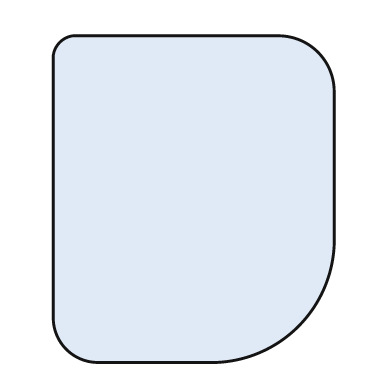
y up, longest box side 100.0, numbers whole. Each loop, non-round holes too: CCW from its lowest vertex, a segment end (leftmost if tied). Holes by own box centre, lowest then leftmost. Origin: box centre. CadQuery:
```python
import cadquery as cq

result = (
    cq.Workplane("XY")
    .moveTo(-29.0, -50.0)
    .lineTo(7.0, -50.0)
    .threePointArc((32.0, -39.0), (43.0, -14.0))
    .lineTo(43.0, 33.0)
    .threePointArc((38.0, 45.0), (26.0, 50.0))
    .lineTo(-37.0, 50.0)
    .threePointArc((-41.0, 48.0), (-43.0, 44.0))
    .lineTo(-43.0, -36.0)
    .threePointArc((-39.0, -46.0), (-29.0, -50.0))
    .close()
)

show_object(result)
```